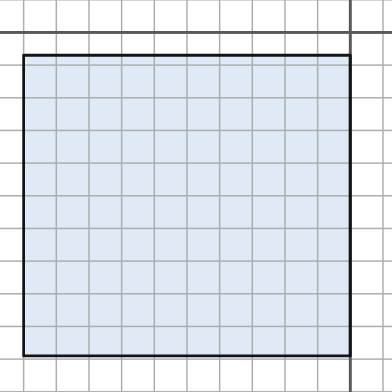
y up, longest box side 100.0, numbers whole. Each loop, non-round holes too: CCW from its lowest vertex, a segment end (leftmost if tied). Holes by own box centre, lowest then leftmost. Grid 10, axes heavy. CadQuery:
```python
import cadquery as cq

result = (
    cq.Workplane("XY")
    .moveTo(-100.0, -99.0)
    .lineTo(0.0, -99.0)
    .lineTo(0.0, -7.0)
    .lineTo(-100.0, -7.0)
    .close()
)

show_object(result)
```